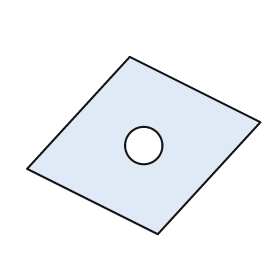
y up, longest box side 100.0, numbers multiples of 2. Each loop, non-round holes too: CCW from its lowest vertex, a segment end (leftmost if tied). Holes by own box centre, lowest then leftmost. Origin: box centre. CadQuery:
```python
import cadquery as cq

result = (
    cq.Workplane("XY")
    .moveTo(6.0, -38.0)
    .lineTo(50.0, 10.0)
    .lineTo(-6.0, 38.0)
    .lineTo(-50.0, -10.0)
    .close()
    .moveTo(0.0, 0.0)
    .circle(8.0)
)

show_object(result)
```